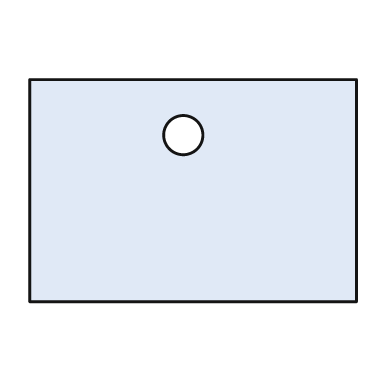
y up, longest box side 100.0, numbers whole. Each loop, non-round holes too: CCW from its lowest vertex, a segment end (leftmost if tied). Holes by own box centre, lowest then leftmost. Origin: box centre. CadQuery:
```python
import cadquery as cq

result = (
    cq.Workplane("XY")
    .moveTo(-50.0, -34.0)
    .lineTo(50.0, -34.0)
    .lineTo(50.0, 34.0)
    .lineTo(-50.0, 34.0)
    .close()
    .moveTo(-3.0, 17.0)
    .circle(6.0)
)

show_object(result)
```